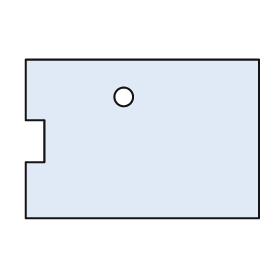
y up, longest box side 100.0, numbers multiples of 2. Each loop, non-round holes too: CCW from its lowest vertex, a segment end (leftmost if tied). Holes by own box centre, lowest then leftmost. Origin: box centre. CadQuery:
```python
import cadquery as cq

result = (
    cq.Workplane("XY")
    .moveTo(-50.0, -34.0)
    .lineTo(50.0, -34.0)
    .lineTo(50.0, 34.0)
    .lineTo(-50.0, 34.0)
    .lineTo(-50.0, 8.0)
    .lineTo(-42.0, 8.0)
    .lineTo(-42.0, -10.0)
    .lineTo(-50.0, -10.0)
    .close()
    .moveTo(-8.0, 18.0)
    .circle(4.0)
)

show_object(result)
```